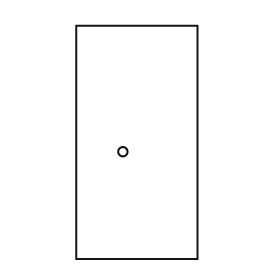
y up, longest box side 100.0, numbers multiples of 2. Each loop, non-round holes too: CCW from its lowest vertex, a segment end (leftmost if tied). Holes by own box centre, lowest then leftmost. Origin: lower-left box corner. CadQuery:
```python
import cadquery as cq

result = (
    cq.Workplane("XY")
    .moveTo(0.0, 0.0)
    .lineTo(52.0, 0.0)
    .lineTo(52.0, 100.0)
    .lineTo(0.0, 100.0)
    .close()
    .moveTo(20.0, 46.0)
    .circle(2.0)
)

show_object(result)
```